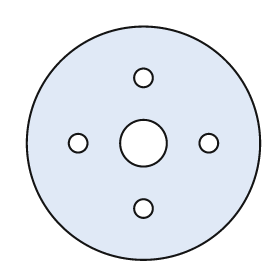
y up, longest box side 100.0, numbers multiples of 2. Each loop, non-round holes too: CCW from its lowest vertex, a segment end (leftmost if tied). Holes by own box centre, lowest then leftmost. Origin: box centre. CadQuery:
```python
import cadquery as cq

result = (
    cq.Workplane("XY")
    .moveTo(0.0, 0.0)
    .circle(50.0)
    .moveTo(0.0, -28.0)
    .circle(4.0)
    .moveTo(-28.0, 0.0)
    .circle(4.0)
    .moveTo(0.0, 0.0)
    .circle(10.0)
    .moveTo(28.0, 0.0)
    .circle(4.0)
    .moveTo(0.0, 28.0)
    .circle(4.0)
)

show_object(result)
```